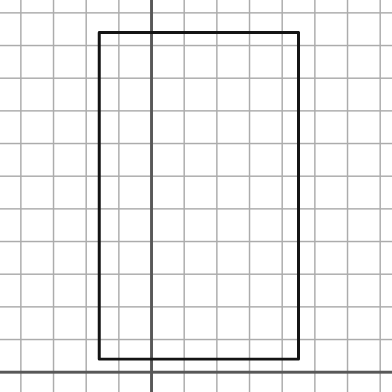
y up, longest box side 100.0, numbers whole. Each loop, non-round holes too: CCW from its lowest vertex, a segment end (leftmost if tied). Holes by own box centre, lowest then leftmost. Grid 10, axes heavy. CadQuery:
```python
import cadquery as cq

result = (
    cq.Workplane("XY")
    .moveTo(-16.0, 4.0)
    .lineTo(45.0, 4.0)
    .lineTo(45.0, 104.0)
    .lineTo(-16.0, 104.0)
    .close()
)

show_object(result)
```